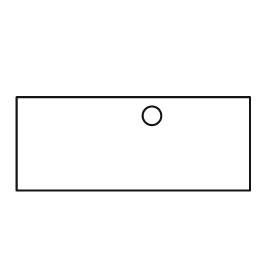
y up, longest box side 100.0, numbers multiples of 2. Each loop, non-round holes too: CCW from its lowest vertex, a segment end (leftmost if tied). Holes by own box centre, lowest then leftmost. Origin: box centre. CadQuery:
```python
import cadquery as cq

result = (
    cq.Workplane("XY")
    .moveTo(-50.0, -20.0)
    .lineTo(50.0, -20.0)
    .lineTo(50.0, 20.0)
    .lineTo(-50.0, 20.0)
    .close()
    .moveTo(8.0, 12.0)
    .circle(4.0)
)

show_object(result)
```